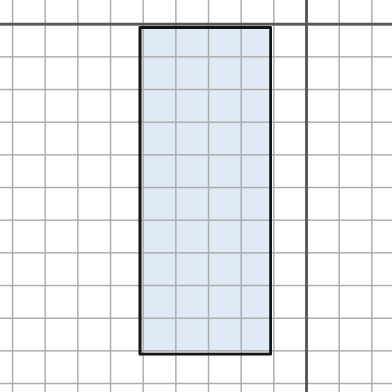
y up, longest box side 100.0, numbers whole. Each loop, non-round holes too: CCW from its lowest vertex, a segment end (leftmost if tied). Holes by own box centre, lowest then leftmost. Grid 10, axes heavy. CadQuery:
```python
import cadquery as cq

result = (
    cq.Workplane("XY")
    .moveTo(-51.0, -101.0)
    .lineTo(-11.0, -101.0)
    .lineTo(-11.0, -1.0)
    .lineTo(-51.0, -1.0)
    .close()
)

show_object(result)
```